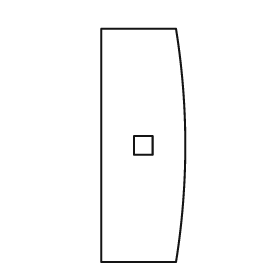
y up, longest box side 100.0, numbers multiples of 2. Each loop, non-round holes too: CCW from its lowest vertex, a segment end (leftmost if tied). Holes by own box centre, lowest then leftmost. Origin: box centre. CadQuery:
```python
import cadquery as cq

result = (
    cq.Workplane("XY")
    .moveTo(-18.0, -50.0)
    .lineTo(14.0, -50.0)
    .threePointArc((18.0, 0.0), (14.0, 50.0))
    .lineTo(-18.0, 50.0)
    .close()
    .moveTo(-4.0, -4.0)
    .lineTo(4.0, -4.0)
    .lineTo(4.0, 4.0)
    .lineTo(-4.0, 4.0)
    .close()
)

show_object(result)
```